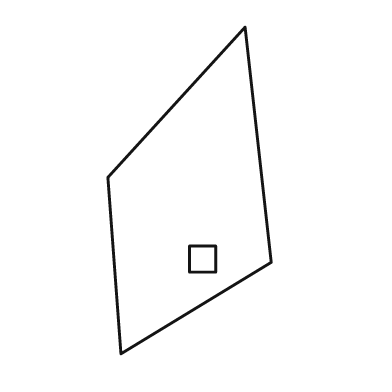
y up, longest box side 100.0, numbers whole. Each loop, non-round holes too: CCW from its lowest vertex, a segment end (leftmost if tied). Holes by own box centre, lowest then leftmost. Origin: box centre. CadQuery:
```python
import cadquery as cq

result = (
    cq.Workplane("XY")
    .moveTo(-21.0, -50.0)
    .lineTo(25.0, -22.0)
    .lineTo(17.0, 50.0)
    .lineTo(-25.0, 4.0)
    .close()
    .moveTo(0.0, -25.0)
    .lineTo(8.0, -25.0)
    .lineTo(8.0, -17.0)
    .lineTo(0.0, -17.0)
    .close()
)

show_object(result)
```